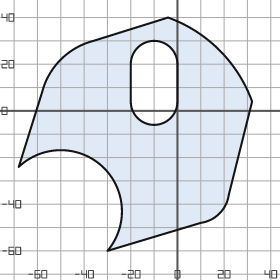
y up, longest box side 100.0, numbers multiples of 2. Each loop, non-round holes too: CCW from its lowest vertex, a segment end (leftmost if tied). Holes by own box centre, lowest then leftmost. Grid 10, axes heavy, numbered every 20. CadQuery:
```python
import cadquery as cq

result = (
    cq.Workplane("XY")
    .moveTo(-30.0, -60.0)
    .lineTo(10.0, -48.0)
    .threePointArc((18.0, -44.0), (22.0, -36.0))
    .lineTo(32.0, 4.0)
    .threePointArc((18.0, 26.0), (-4.0, 40.0))
    .lineTo(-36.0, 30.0)
    .threePointArc((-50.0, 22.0), (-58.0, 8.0))
    .lineTo(-68.0, -24.0)
    .threePointArc((-32.0, -24.0), (-30.0, -60.0))
    .close()
    .moveTo(-20.0, 4.0)
    .threePointArc((-10.0, -6.0), (0.0, 4.0))
    .lineTo(0.0, 20.0)
    .threePointArc((-10.0, 30.0), (-20.0, 20.0))
    .close()
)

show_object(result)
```